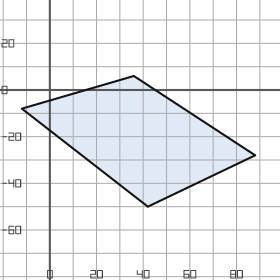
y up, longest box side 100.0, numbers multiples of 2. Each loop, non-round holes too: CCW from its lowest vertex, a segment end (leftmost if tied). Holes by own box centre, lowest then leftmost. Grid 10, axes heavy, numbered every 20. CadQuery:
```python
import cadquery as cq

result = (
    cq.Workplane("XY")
    .moveTo(42.0, -50.0)
    .lineTo(88.0, -28.0)
    .lineTo(36.0, 6.0)
    .lineTo(-12.0, -8.0)
    .close()
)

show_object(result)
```